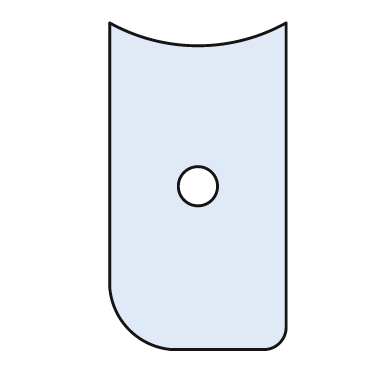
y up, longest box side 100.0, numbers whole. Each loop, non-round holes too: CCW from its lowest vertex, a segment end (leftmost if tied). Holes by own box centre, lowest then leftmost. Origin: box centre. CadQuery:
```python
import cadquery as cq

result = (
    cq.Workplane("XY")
    .moveTo(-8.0, -50.0)
    .lineTo(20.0, -50.0)
    .threePointArc((25.0, -48.0), (27.0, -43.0))
    .lineTo(27.0, 50.0)
    .threePointArc((0.0, 43.0), (-27.0, 50.0))
    .lineTo(-27.0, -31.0)
    .threePointArc((-21.0, -44.0), (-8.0, -50.0))
    .close()
    .moveTo(0.0, 0.0)
    .circle(6.0)
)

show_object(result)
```